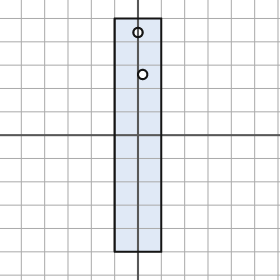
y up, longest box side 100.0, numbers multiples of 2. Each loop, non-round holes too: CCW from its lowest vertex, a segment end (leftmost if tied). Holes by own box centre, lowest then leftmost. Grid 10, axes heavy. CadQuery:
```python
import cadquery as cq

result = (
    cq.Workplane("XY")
    .moveTo(-10.0, -50.0)
    .lineTo(10.0, -50.0)
    .lineTo(10.0, 50.0)
    .lineTo(-10.0, 50.0)
    .close()
    .moveTo(2.0, 26.0)
    .circle(2.0)
    .moveTo(0.0, 44.0)
    .circle(2.0)
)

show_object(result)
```